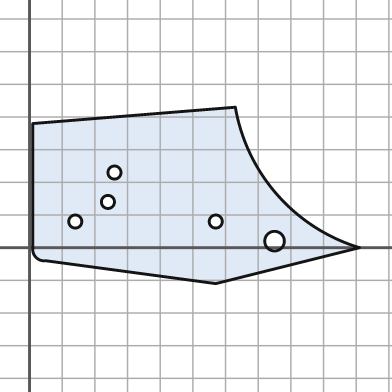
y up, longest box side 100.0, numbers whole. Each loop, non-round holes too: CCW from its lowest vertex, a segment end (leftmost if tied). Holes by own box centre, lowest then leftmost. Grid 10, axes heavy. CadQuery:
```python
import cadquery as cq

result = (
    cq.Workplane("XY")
    .moveTo(57.0, -11.0)
    .lineTo(101.0, 0.0)
    .threePointArc((76.0, 16.0), (63.0, 43.0))
    .lineTo(1.0, 38.0)
    .lineTo(1.0, 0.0)
    .threePointArc((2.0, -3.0), (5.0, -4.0))
    .close()
    .moveTo(75.0, 2.0)
    .circle(3.0)
    .moveTo(14.0, 8.0)
    .circle(2.0)
    .moveTo(57.0, 8.0)
    .circle(2.0)
    .moveTo(24.0, 14.0)
    .circle(2.0)
    .moveTo(26.0, 23.0)
    .circle(2.0)
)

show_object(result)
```